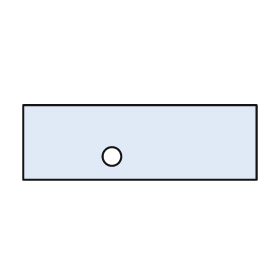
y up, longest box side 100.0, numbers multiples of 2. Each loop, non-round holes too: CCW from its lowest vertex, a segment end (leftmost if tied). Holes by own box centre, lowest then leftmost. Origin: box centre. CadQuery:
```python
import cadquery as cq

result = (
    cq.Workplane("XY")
    .moveTo(-50.0, -16.0)
    .lineTo(50.0, -16.0)
    .lineTo(50.0, 16.0)
    .lineTo(-50.0, 16.0)
    .close()
    .moveTo(-12.0, -6.0)
    .circle(4.0)
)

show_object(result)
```